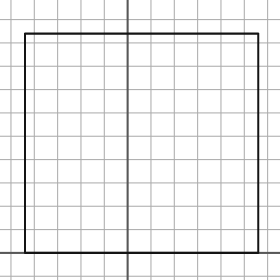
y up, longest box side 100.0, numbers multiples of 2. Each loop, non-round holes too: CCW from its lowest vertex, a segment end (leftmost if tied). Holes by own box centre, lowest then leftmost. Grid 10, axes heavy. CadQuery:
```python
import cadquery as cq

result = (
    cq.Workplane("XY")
    .moveTo(-44.0, 0.0)
    .lineTo(56.0, 0.0)
    .lineTo(56.0, 94.0)
    .lineTo(-44.0, 94.0)
    .close()
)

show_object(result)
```